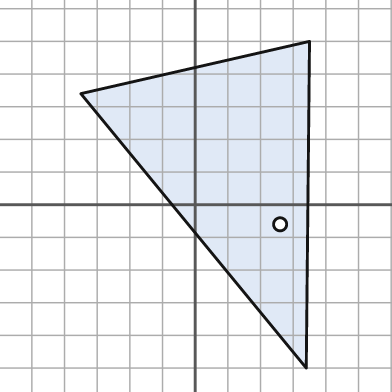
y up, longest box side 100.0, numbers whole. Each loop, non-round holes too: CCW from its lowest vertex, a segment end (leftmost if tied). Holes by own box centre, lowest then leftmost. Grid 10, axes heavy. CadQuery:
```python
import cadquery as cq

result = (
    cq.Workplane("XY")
    .moveTo(34.0, -50.0)
    .lineTo(35.0, 50.0)
    .lineTo(-35.0, 34.0)
    .close()
    .moveTo(26.0, -6.0)
    .circle(2.0)
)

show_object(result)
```